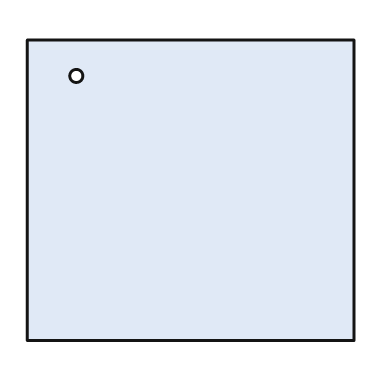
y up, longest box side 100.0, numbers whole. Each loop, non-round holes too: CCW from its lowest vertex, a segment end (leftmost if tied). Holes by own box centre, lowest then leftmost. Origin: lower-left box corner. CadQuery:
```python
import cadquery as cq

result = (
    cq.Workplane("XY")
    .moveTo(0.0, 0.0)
    .lineTo(100.0, 0.0)
    .lineTo(100.0, 92.0)
    .lineTo(0.0, 92.0)
    .close()
    .moveTo(15.0, 81.0)
    .circle(2.0)
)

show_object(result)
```